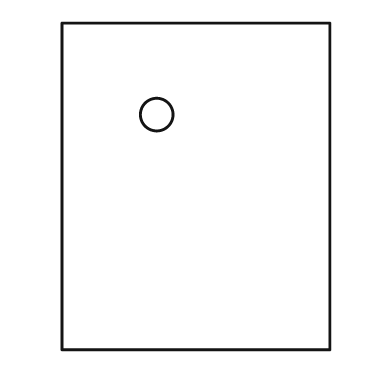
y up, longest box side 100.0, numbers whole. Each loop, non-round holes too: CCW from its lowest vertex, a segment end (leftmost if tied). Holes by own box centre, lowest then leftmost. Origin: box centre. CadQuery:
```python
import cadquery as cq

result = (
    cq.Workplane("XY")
    .moveTo(-41.0, -50.0)
    .lineTo(41.0, -50.0)
    .lineTo(41.0, 50.0)
    .lineTo(-41.0, 50.0)
    .close()
    .moveTo(-12.0, 22.0)
    .circle(5.0)
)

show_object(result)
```